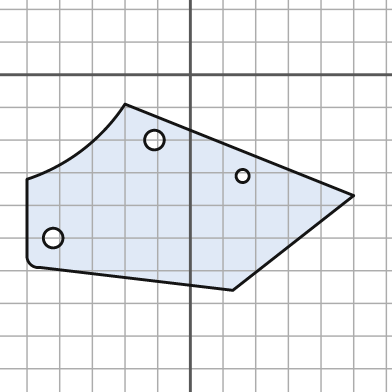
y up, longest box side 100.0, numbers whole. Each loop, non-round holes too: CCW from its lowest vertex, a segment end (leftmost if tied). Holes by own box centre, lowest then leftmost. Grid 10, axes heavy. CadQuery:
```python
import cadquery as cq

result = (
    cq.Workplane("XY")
    .moveTo(13.0, -66.0)
    .lineTo(50.0, -37.0)
    .lineTo(-20.0, -9.0)
    .threePointArc((-33.0, -23.0), (-50.0, -32.0))
    .lineTo(-50.0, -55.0)
    .threePointArc((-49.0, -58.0), (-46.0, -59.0))
    .close()
    .moveTo(-42.0, -50.0)
    .circle(3.0)
    .moveTo(16.0, -31.0)
    .circle(2.0)
    .moveTo(-11.0, -20.0)
    .circle(3.0)
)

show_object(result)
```